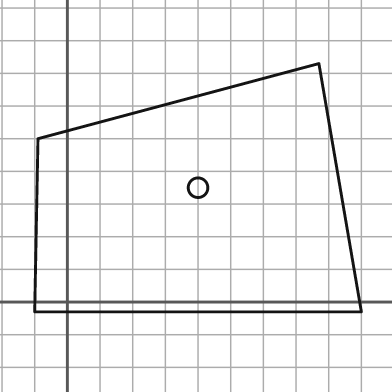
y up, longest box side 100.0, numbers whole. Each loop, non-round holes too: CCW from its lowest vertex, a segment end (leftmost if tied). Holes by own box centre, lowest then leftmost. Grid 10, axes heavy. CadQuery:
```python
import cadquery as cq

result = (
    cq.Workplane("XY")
    .moveTo(-10.0, -3.0)
    .lineTo(90.0, -3.0)
    .lineTo(77.0, 73.0)
    .lineTo(-9.0, 50.0)
    .close()
    .moveTo(40.0, 35.0)
    .circle(3.0)
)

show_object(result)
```